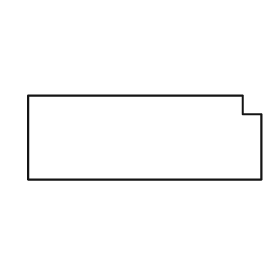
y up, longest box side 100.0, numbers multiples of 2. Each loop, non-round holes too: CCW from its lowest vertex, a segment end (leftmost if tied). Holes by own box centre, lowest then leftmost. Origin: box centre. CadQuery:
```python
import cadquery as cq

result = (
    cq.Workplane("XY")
    .moveTo(-50.0, -18.0)
    .lineTo(50.0, -18.0)
    .lineTo(50.0, 10.0)
    .lineTo(42.0, 10.0)
    .lineTo(42.0, 18.0)
    .lineTo(-50.0, 18.0)
    .close()
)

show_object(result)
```